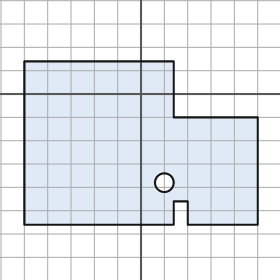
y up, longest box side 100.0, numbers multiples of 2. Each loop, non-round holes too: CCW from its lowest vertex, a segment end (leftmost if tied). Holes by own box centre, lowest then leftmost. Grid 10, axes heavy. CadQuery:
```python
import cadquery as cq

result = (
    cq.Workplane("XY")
    .moveTo(-50.0, -56.0)
    .lineTo(14.0, -56.0)
    .lineTo(14.0, -46.0)
    .lineTo(20.0, -46.0)
    .lineTo(20.0, -56.0)
    .lineTo(50.0, -56.0)
    .lineTo(50.0, -10.0)
    .lineTo(14.0, -10.0)
    .lineTo(14.0, 14.0)
    .lineTo(-50.0, 14.0)
    .close()
    .moveTo(10.0, -38.0)
    .circle(4.0)
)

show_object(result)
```